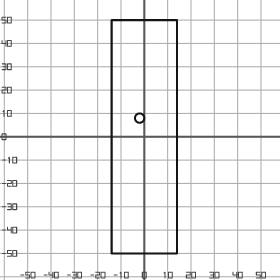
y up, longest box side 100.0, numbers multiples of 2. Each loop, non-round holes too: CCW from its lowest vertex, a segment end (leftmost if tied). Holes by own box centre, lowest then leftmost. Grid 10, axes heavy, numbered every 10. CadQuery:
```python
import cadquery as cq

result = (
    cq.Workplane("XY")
    .moveTo(-14.0, -50.0)
    .lineTo(14.0, -50.0)
    .lineTo(14.0, 50.0)
    .lineTo(-14.0, 50.0)
    .close()
    .moveTo(-2.0, 8.0)
    .circle(2.0)
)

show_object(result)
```